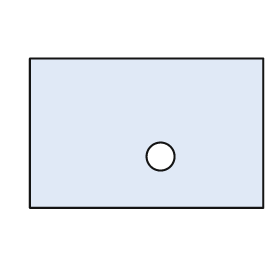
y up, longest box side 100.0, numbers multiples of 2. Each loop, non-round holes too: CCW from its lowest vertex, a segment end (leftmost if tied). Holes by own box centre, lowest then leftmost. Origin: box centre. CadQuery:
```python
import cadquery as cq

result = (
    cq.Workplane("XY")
    .moveTo(-50.0, -32.0)
    .lineTo(50.0, -32.0)
    .lineTo(50.0, 32.0)
    .lineTo(-50.0, 32.0)
    .close()
    .moveTo(6.0, -10.0)
    .circle(6.0)
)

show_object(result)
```